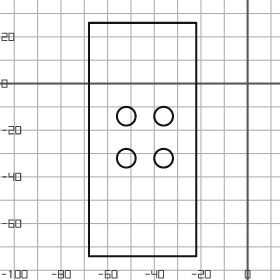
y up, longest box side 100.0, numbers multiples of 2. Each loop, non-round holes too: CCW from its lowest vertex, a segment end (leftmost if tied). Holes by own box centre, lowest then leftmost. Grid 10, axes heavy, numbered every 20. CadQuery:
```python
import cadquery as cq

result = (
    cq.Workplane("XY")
    .moveTo(-68.0, -74.0)
    .lineTo(-22.0, -74.0)
    .lineTo(-22.0, 26.0)
    .lineTo(-68.0, 26.0)
    .close()
    .moveTo(-52.0, -32.0)
    .circle(4.0)
    .moveTo(-36.0, -32.0)
    .circle(4.0)
    .moveTo(-52.0, -14.0)
    .circle(4.0)
    .moveTo(-36.0, -14.0)
    .circle(4.0)
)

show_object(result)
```